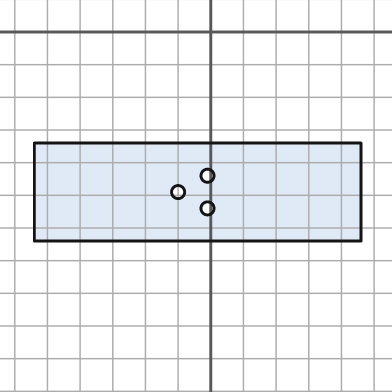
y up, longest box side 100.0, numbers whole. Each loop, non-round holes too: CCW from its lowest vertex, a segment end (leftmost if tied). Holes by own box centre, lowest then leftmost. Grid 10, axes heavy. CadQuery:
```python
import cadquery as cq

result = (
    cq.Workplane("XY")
    .moveTo(-54.0, -64.0)
    .lineTo(46.0, -64.0)
    .lineTo(46.0, -34.0)
    .lineTo(-54.0, -34.0)
    .close()
    .moveTo(-1.0, -54.0)
    .circle(2.0)
    .moveTo(-10.0, -49.0)
    .circle(2.0)
    .moveTo(-1.0, -44.0)
    .circle(2.0)
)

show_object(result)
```